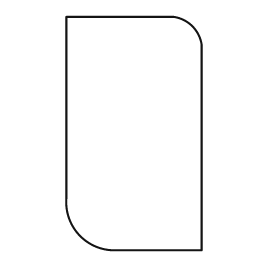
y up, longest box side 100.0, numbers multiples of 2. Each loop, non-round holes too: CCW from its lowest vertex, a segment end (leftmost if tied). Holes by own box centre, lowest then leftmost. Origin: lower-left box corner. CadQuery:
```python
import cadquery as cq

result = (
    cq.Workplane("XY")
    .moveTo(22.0, 0.0)
    .lineTo(58.0, 0.0)
    .lineTo(58.0, 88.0)
    .threePointArc((54.0, 96.0), (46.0, 100.0))
    .lineTo(0.0, 100.0)
    .lineTo(0.0, 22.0)
    .threePointArc((6.0, 6.0), (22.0, 0.0))
    .close()
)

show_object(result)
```